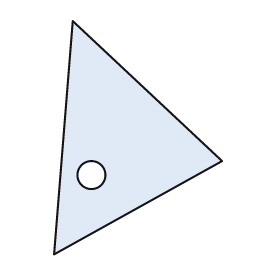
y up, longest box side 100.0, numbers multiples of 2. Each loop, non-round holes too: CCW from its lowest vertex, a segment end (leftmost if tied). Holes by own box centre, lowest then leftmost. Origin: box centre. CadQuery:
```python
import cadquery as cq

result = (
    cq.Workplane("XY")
    .moveTo(-36.0, -50.0)
    .lineTo(36.0, -10.0)
    .lineTo(-28.0, 50.0)
    .close()
    .moveTo(-20.0, -16.0)
    .circle(6.0)
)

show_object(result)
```